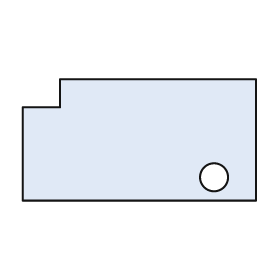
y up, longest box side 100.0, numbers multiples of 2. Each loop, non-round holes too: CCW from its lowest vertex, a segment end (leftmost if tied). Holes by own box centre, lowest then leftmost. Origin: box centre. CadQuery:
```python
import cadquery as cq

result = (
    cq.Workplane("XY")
    .moveTo(-50.0, -26.0)
    .lineTo(50.0, -26.0)
    .lineTo(50.0, 26.0)
    .lineTo(-34.0, 26.0)
    .lineTo(-34.0, 14.0)
    .lineTo(-50.0, 14.0)
    .close()
    .moveTo(32.0, -16.0)
    .circle(6.0)
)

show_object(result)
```